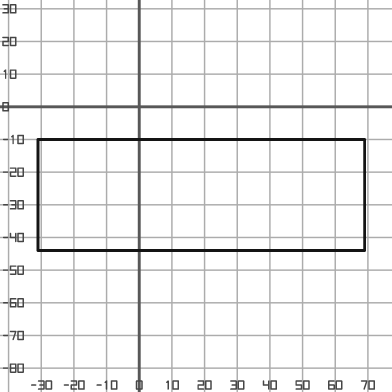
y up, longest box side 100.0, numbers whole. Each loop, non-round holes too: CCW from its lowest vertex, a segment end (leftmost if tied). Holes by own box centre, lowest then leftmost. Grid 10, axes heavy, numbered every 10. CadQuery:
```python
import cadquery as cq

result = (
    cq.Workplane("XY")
    .moveTo(-31.0, -44.0)
    .lineTo(69.0, -44.0)
    .lineTo(69.0, -10.0)
    .lineTo(-31.0, -10.0)
    .close()
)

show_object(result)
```